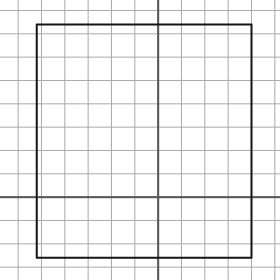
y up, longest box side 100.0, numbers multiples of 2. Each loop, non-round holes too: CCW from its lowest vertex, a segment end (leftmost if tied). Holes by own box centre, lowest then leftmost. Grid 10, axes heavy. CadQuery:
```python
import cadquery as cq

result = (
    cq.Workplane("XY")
    .moveTo(-52.0, -26.0)
    .lineTo(40.0, -26.0)
    .lineTo(40.0, 74.0)
    .lineTo(-52.0, 74.0)
    .close()
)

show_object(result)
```